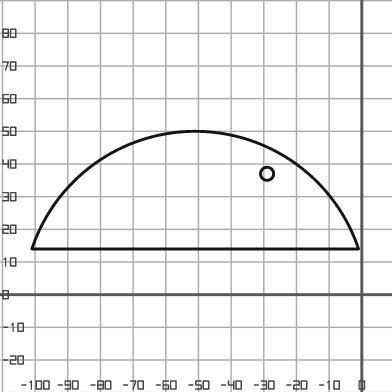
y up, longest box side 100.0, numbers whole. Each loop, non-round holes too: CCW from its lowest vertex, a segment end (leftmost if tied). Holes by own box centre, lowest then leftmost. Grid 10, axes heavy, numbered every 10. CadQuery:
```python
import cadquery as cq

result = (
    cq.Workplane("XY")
    .moveTo(-101.0, 14.0)
    .lineTo(-1.0, 14.0)
    .threePointArc((-51.0, 50.0), (-101.0, 14.0))
    .close()
    .moveTo(-29.0, 37.0)
    .circle(2.0)
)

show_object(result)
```